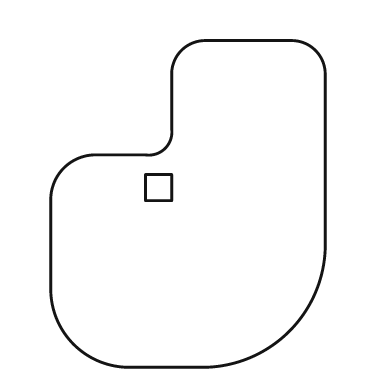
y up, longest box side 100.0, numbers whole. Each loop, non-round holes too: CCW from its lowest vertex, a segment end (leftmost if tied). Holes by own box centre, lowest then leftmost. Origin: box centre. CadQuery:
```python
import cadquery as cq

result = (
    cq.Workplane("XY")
    .moveTo(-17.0, -50.0)
    .lineTo(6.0, -50.0)
    .threePointArc((31.0, -39.0), (42.0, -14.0))
    .lineTo(42.0, 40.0)
    .threePointArc((39.0, 47.0), (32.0, 50.0))
    .lineTo(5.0, 50.0)
    .threePointArc((-2.0, 47.0), (-5.0, 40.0))
    .lineTo(-5.0, 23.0)
    .threePointArc((-7.0, 17.0), (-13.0, 15.0))
    .lineTo(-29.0, 15.0)
    .threePointArc((-38.0, 11.0), (-42.0, 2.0))
    .lineTo(-42.0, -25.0)
    .threePointArc((-35.0, -43.0), (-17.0, -50.0))
    .close()
    .moveTo(-13.0, 1.0)
    .lineTo(-5.0, 1.0)
    .lineTo(-5.0, 9.0)
    .lineTo(-13.0, 9.0)
    .close()
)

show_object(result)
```